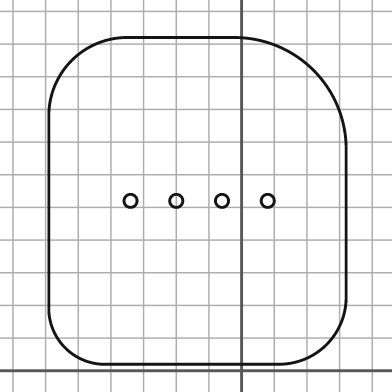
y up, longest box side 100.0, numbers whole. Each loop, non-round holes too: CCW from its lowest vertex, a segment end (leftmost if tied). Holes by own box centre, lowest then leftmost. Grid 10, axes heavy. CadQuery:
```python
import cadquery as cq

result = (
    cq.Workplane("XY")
    .moveTo(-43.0, 2.0)
    .lineTo(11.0, 2.0)
    .threePointArc((26.0, 8.0), (32.0, 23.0))
    .lineTo(32.0, 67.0)
    .threePointArc((22.0, 92.0), (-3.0, 102.0))
    .lineTo(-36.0, 102.0)
    .threePointArc((-52.0, 95.0), (-59.0, 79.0))
    .lineTo(-59.0, 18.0)
    .threePointArc((-54.0, 7.0), (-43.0, 2.0))
    .close()
    .moveTo(-34.0, 52.0)
    .circle(2.0)
    .moveTo(-20.0, 52.0)
    .circle(2.0)
    .moveTo(-6.0, 52.0)
    .circle(2.0)
    .moveTo(8.0, 52.0)
    .circle(2.0)
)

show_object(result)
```